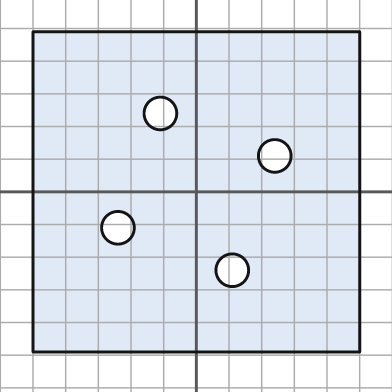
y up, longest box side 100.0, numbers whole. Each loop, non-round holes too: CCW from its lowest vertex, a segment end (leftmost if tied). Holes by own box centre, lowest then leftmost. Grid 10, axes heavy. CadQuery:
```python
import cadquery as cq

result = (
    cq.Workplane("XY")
    .moveTo(-50.0, -49.0)
    .lineTo(50.0, -49.0)
    .lineTo(50.0, 49.0)
    .lineTo(-50.0, 49.0)
    .close()
    .moveTo(11.0, -24.0)
    .circle(5.0)
    .moveTo(-24.0, -11.0)
    .circle(5.0)
    .moveTo(24.0, 11.0)
    .circle(5.0)
    .moveTo(-11.0, 24.0)
    .circle(5.0)
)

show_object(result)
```